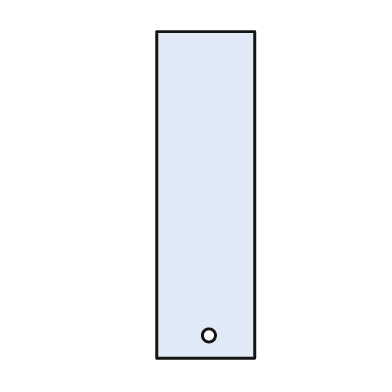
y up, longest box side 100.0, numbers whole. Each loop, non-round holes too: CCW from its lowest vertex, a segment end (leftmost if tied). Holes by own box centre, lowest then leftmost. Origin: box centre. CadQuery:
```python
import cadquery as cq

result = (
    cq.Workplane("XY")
    .moveTo(-15.0, -50.0)
    .lineTo(15.0, -50.0)
    .lineTo(15.0, 50.0)
    .lineTo(-15.0, 50.0)
    .close()
    .moveTo(1.0, -43.0)
    .circle(2.0)
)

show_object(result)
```